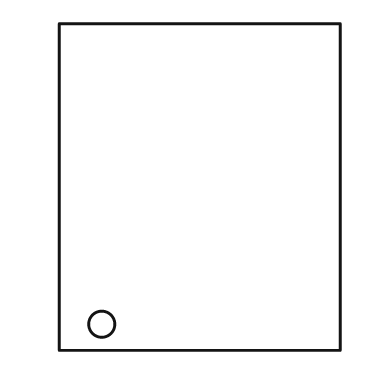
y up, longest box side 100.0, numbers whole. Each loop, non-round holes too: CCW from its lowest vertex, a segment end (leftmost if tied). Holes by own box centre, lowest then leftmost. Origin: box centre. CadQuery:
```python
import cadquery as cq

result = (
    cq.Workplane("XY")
    .moveTo(-43.0, -50.0)
    .lineTo(43.0, -50.0)
    .lineTo(43.0, 50.0)
    .lineTo(-43.0, 50.0)
    .close()
    .moveTo(-30.0, -42.0)
    .circle(4.0)
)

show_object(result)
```